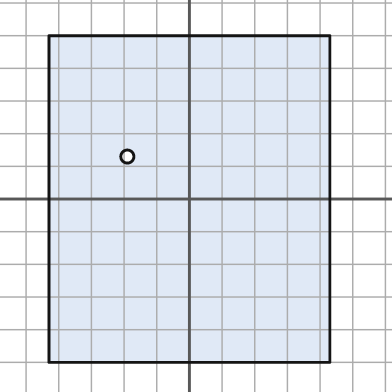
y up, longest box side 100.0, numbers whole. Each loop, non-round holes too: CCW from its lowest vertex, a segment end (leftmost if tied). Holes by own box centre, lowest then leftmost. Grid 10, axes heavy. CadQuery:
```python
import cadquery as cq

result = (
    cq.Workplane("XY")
    .moveTo(-43.0, -50.0)
    .lineTo(43.0, -50.0)
    .lineTo(43.0, 50.0)
    .lineTo(-43.0, 50.0)
    .close()
    .moveTo(-19.0, 13.0)
    .circle(2.0)
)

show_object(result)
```